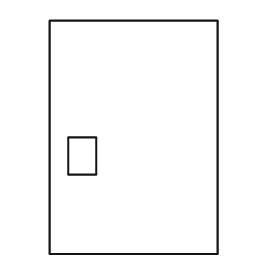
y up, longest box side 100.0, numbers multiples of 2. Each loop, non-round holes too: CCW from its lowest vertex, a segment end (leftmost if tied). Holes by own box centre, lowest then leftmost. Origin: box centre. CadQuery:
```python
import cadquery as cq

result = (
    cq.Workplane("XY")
    .moveTo(-36.0, -50.0)
    .lineTo(36.0, -50.0)
    .lineTo(36.0, 50.0)
    .lineTo(-36.0, 50.0)
    .close()
    .moveTo(-28.0, -16.0)
    .lineTo(-16.0, -16.0)
    .lineTo(-16.0, 0.0)
    .lineTo(-28.0, 0.0)
    .close()
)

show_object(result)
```